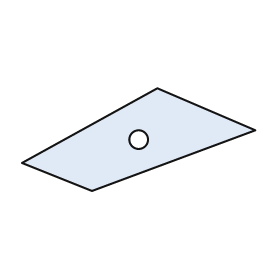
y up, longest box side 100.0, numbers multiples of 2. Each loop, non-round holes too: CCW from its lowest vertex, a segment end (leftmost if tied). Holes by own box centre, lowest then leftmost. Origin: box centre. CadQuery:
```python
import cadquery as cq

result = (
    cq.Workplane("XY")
    .moveTo(-20.0, -22.0)
    .lineTo(50.0, 4.0)
    .lineTo(8.0, 22.0)
    .lineTo(-50.0, -10.0)
    .close()
    .moveTo(0.0, 0.0)
    .circle(4.0)
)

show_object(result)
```